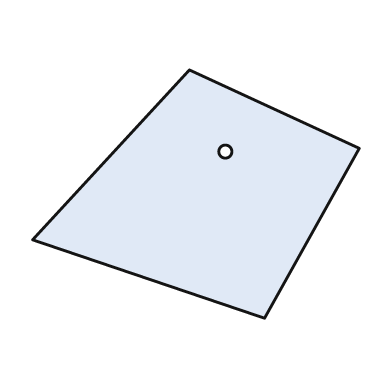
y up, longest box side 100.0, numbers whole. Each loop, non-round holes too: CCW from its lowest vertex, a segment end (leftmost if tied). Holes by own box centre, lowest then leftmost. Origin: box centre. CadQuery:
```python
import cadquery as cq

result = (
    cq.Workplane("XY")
    .moveTo(21.0, -38.0)
    .lineTo(50.0, 14.0)
    .lineTo(-2.0, 38.0)
    .lineTo(-50.0, -14.0)
    .close()
    .moveTo(9.0, 13.0)
    .circle(2.0)
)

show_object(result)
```